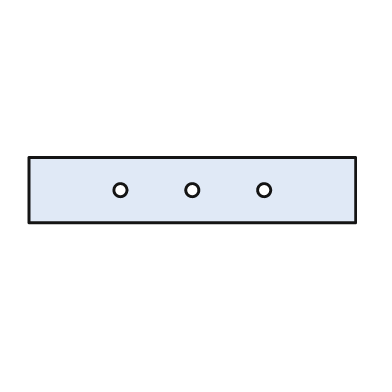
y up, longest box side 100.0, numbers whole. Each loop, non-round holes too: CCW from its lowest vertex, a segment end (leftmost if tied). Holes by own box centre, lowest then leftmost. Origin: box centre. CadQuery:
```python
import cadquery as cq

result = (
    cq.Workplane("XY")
    .moveTo(-50.0, -10.0)
    .lineTo(50.0, -10.0)
    .lineTo(50.0, 10.0)
    .lineTo(-50.0, 10.0)
    .close()
    .moveTo(-22.0, 0.0)
    .circle(2.0)
    .moveTo(0.0, 0.0)
    .circle(2.0)
    .moveTo(22.0, 0.0)
    .circle(2.0)
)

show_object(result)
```